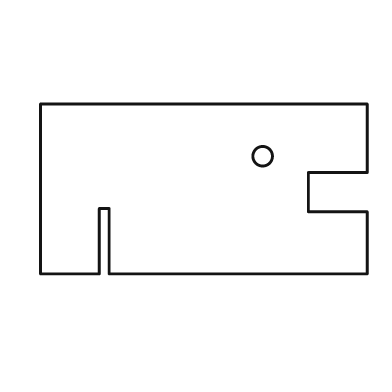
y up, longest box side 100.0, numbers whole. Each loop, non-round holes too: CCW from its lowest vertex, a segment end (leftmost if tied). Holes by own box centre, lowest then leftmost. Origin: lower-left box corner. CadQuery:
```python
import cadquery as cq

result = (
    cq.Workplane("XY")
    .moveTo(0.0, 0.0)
    .lineTo(18.0, 0.0)
    .lineTo(18.0, 20.0)
    .lineTo(21.0, 20.0)
    .lineTo(21.0, 0.0)
    .lineTo(100.0, 0.0)
    .lineTo(100.0, 19.0)
    .lineTo(82.0, 19.0)
    .lineTo(82.0, 31.0)
    .lineTo(100.0, 31.0)
    .lineTo(100.0, 52.0)
    .lineTo(0.0, 52.0)
    .close()
    .moveTo(68.0, 36.0)
    .circle(3.0)
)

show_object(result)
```